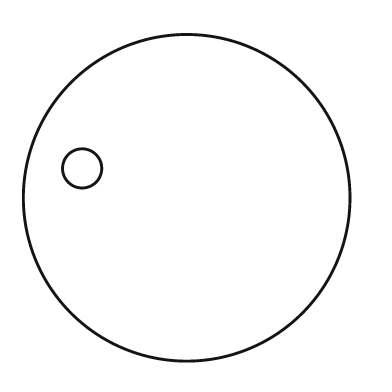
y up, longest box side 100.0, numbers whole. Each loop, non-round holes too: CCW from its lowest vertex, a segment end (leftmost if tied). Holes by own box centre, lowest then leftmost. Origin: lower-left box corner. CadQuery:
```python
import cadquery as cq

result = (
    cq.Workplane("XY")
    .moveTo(50.0, 50.0)
    .circle(50.0)
    .moveTo(18.0, 59.0)
    .circle(6.0)
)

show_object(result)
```